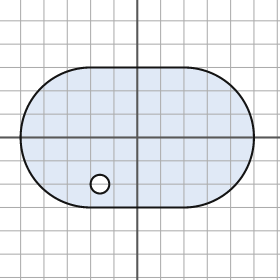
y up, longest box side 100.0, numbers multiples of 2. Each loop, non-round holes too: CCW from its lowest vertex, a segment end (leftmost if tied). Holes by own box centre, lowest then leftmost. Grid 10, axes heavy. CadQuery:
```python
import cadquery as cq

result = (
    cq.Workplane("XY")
    .moveTo(-20.0, -30.0)
    .lineTo(20.0, -30.0)
    .threePointArc((50.0, 0.0), (20.0, 30.0))
    .lineTo(-20.0, 30.0)
    .threePointArc((-50.0, 0.0), (-20.0, -30.0))
    .close()
    .moveTo(-16.0, -20.0)
    .circle(4.0)
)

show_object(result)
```